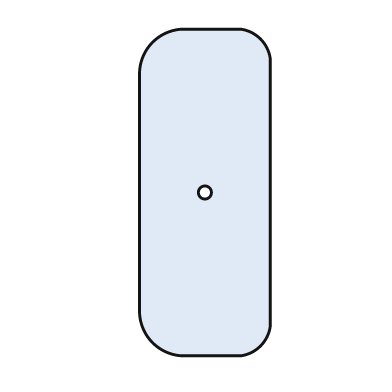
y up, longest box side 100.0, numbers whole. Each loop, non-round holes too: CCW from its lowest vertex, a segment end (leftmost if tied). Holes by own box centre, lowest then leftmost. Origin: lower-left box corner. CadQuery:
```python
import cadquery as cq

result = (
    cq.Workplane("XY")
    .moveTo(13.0, 0.0)
    .lineTo(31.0, 0.0)
    .threePointArc((37.0, 3.0), (40.0, 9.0))
    .lineTo(40.0, 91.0)
    .threePointArc((37.0, 97.0), (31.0, 100.0))
    .lineTo(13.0, 100.0)
    .threePointArc((4.0, 96.0), (0.0, 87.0))
    .lineTo(0.0, 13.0)
    .threePointArc((4.0, 4.0), (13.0, 0.0))
    .close()
    .moveTo(20.0, 50.0)
    .circle(2.0)
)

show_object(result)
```